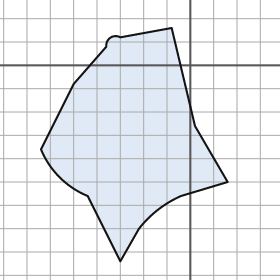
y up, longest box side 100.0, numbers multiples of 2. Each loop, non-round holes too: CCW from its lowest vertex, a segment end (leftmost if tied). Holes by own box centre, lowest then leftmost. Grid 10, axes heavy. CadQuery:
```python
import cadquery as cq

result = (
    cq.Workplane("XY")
    .moveTo(-30.0, -84.0)
    .lineTo(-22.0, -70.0)
    .threePointArc((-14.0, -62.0), (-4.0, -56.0))
    .lineTo(16.0, -50.0)
    .lineTo(2.0, -26.0)
    .lineTo(-8.0, 16.0)
    .lineTo(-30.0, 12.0)
    .threePointArc((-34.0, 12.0), (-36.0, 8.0))
    .lineTo(-50.0, -8.0)
    .lineTo(-64.0, -36.0)
    .threePointArc((-56.0, -48.0), (-44.0, -56.0))
    .close()
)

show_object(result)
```